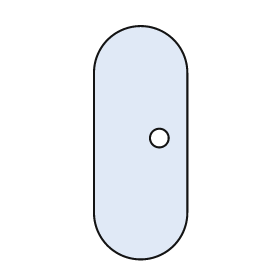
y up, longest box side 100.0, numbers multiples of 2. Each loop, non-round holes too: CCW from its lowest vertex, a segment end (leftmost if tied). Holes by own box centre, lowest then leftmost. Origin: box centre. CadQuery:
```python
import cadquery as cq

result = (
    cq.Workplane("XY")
    .moveTo(-20.0, -30.0)
    .threePointArc((0.0, -50.0), (20.0, -30.0))
    .lineTo(20.0, 30.0)
    .threePointArc((0.0, 50.0), (-20.0, 30.0))
    .close()
    .moveTo(8.0, 2.0)
    .circle(4.0)
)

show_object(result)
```